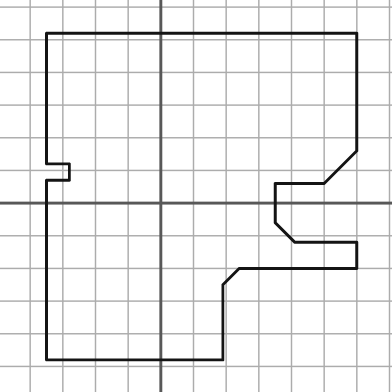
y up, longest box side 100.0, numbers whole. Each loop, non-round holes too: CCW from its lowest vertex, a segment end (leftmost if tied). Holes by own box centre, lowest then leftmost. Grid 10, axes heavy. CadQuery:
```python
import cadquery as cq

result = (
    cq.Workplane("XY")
    .moveTo(-35.0, -48.0)
    .lineTo(19.0, -48.0)
    .lineTo(19.0, -25.0)
    .lineTo(24.0, -20.0)
    .lineTo(60.0, -20.0)
    .lineTo(60.0, -12.0)
    .lineTo(41.0, -12.0)
    .lineTo(35.0, -6.0)
    .lineTo(35.0, 6.0)
    .lineTo(50.0, 6.0)
    .lineTo(60.0, 16.0)
    .lineTo(60.0, 52.0)
    .lineTo(-35.0, 52.0)
    .lineTo(-35.0, 12.0)
    .lineTo(-28.0, 12.0)
    .lineTo(-28.0, 7.0)
    .lineTo(-35.0, 7.0)
    .close()
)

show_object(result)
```